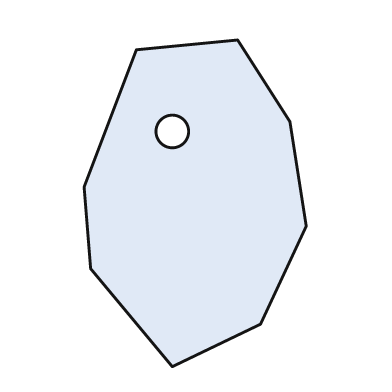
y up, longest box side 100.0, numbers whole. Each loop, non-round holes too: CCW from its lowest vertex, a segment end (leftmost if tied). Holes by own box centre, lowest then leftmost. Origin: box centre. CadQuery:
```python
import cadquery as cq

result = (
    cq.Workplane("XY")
    .moveTo(-7.0, -50.0)
    .lineTo(20.0, -37.0)
    .lineTo(34.0, -7.0)
    .lineTo(29.0, 25.0)
    .lineTo(13.0, 50.0)
    .lineTo(-18.0, 47.0)
    .lineTo(-34.0, 5.0)
    .lineTo(-32.0, -20.0)
    .close()
    .moveTo(-7.0, 22.0)
    .circle(5.0)
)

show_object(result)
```